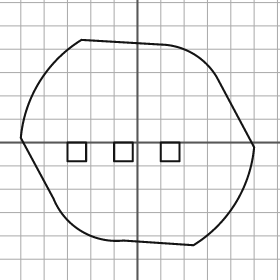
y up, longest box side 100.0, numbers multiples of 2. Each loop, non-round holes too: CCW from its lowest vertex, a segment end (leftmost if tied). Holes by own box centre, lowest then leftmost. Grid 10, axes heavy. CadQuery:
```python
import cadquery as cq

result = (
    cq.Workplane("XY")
    .moveTo(24.0, -44.0)
    .threePointArc((42.0, -26.0), (50.0, -2.0))
    .lineTo(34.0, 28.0)
    .threePointArc((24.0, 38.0), (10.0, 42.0))
    .lineTo(-24.0, 44.0)
    .threePointArc((-42.0, 26.0), (-50.0, 2.0))
    .lineTo(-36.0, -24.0)
    .threePointArc((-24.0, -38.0), (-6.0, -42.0))
    .close()
    .moveTo(-30.0, -8.0)
    .lineTo(-22.0, -8.0)
    .lineTo(-22.0, 0.0)
    .lineTo(-30.0, 0.0)
    .close()
    .moveTo(-10.0, -8.0)
    .lineTo(-2.0, -8.0)
    .lineTo(-2.0, 0.0)
    .lineTo(-10.0, 0.0)
    .close()
    .moveTo(10.0, -8.0)
    .lineTo(18.0, -8.0)
    .lineTo(18.0, 0.0)
    .lineTo(10.0, 0.0)
    .close()
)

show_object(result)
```